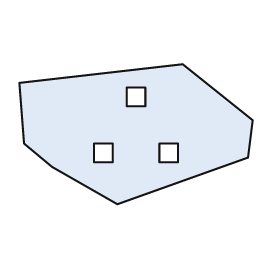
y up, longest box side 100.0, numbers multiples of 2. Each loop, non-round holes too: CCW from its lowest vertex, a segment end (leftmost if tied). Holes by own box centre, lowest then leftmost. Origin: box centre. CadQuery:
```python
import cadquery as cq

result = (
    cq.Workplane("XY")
    .moveTo(-8.0, -30.0)
    .lineTo(48.0, -10.0)
    .lineTo(50.0, 6.0)
    .lineTo(20.0, 30.0)
    .lineTo(-50.0, 22.0)
    .lineTo(-48.0, -4.0)
    .lineTo(-36.0, -14.0)
    .close()
    .moveTo(-18.0, -12.0)
    .lineTo(-10.0, -12.0)
    .lineTo(-10.0, -4.0)
    .lineTo(-18.0, -4.0)
    .close()
    .moveTo(10.0, -12.0)
    .lineTo(18.0, -12.0)
    .lineTo(18.0, -4.0)
    .lineTo(10.0, -4.0)
    .close()
    .moveTo(-4.0, 12.0)
    .lineTo(4.0, 12.0)
    .lineTo(4.0, 20.0)
    .lineTo(-4.0, 20.0)
    .close()
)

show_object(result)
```